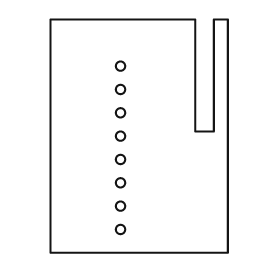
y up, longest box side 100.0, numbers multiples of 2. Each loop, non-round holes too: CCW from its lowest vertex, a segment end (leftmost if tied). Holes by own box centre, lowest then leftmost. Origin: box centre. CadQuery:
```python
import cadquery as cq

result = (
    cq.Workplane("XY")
    .moveTo(-38.0, -50.0)
    .lineTo(38.0, -50.0)
    .lineTo(38.0, 50.0)
    .lineTo(32.0, 50.0)
    .lineTo(32.0, 2.0)
    .lineTo(24.0, 2.0)
    .lineTo(24.0, 50.0)
    .lineTo(-38.0, 50.0)
    .close()
    .moveTo(-8.0, -40.0)
    .circle(2.0)
    .moveTo(-8.0, -30.0)
    .circle(2.0)
    .moveTo(-8.0, -20.0)
    .circle(2.0)
    .moveTo(-8.0, -10.0)
    .circle(2.0)
    .moveTo(-8.0, 0.0)
    .circle(2.0)
    .moveTo(-8.0, 10.0)
    .circle(2.0)
    .moveTo(-8.0, 20.0)
    .circle(2.0)
    .moveTo(-8.0, 30.0)
    .circle(2.0)
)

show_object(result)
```